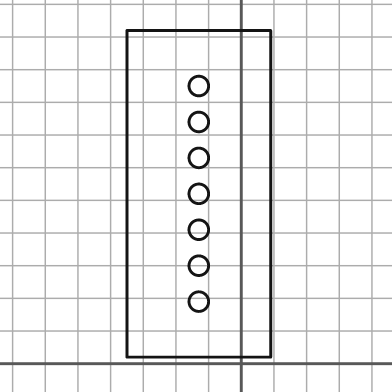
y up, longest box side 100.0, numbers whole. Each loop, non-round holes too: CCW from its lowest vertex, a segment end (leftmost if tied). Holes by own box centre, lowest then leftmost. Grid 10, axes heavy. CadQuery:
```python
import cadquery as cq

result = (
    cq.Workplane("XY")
    .moveTo(-35.0, 2.0)
    .lineTo(9.0, 2.0)
    .lineTo(9.0, 102.0)
    .lineTo(-35.0, 102.0)
    .close()
    .moveTo(-13.0, 19.0)
    .circle(3.0)
    .moveTo(-13.0, 30.0)
    .circle(3.0)
    .moveTo(-13.0, 41.0)
    .circle(3.0)
    .moveTo(-13.0, 52.0)
    .circle(3.0)
    .moveTo(-13.0, 63.0)
    .circle(3.0)
    .moveTo(-13.0, 74.0)
    .circle(3.0)
    .moveTo(-13.0, 85.0)
    .circle(3.0)
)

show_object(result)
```